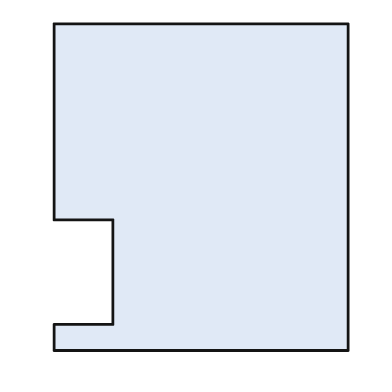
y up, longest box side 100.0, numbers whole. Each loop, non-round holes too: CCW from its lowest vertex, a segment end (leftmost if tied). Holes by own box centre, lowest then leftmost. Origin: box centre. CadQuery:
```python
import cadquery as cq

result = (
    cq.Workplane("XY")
    .moveTo(-45.0, -50.0)
    .lineTo(45.0, -50.0)
    .lineTo(45.0, 50.0)
    .lineTo(-45.0, 50.0)
    .lineTo(-45.0, -10.0)
    .lineTo(-27.0, -10.0)
    .lineTo(-27.0, -42.0)
    .lineTo(-45.0, -42.0)
    .close()
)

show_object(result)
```